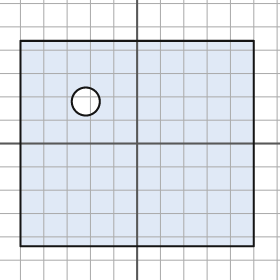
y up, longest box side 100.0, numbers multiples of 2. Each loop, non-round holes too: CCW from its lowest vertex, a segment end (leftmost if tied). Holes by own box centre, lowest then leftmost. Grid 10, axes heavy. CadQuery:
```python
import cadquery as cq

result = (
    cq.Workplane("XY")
    .moveTo(-50.0, -44.0)
    .lineTo(50.0, -44.0)
    .lineTo(50.0, 44.0)
    .lineTo(-50.0, 44.0)
    .close()
    .moveTo(-22.0, 18.0)
    .circle(6.0)
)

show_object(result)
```